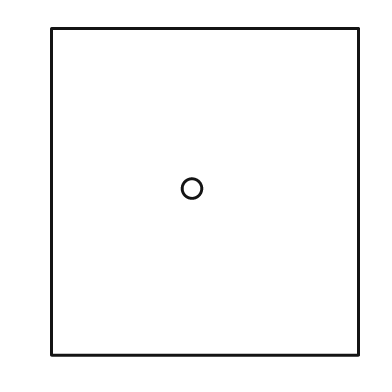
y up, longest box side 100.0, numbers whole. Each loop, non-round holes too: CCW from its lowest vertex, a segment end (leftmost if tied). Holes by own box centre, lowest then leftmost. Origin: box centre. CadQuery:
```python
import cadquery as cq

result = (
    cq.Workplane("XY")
    .moveTo(-47.0, -50.0)
    .lineTo(47.0, -50.0)
    .lineTo(47.0, 50.0)
    .lineTo(-47.0, 50.0)
    .close()
    .moveTo(-4.0, 1.0)
    .circle(3.0)
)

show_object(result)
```